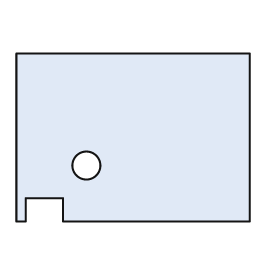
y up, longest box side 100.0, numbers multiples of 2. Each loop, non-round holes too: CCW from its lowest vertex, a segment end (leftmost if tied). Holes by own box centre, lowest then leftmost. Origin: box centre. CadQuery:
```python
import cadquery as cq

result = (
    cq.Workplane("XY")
    .moveTo(-50.0, -36.0)
    .lineTo(-46.0, -36.0)
    .lineTo(-46.0, -26.0)
    .lineTo(-30.0, -26.0)
    .lineTo(-30.0, -36.0)
    .lineTo(50.0, -36.0)
    .lineTo(50.0, 36.0)
    .lineTo(-50.0, 36.0)
    .close()
    .moveTo(-20.0, -12.0)
    .circle(6.0)
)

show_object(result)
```